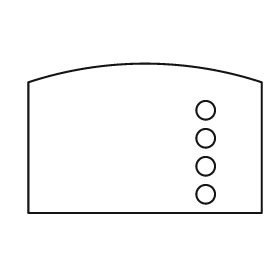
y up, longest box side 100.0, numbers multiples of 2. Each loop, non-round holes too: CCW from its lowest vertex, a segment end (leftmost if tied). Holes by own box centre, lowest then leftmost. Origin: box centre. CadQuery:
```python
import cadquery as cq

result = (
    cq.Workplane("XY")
    .moveTo(-50.0, -32.0)
    .lineTo(50.0, -32.0)
    .lineTo(50.0, 24.0)
    .threePointArc((0.0, 32.0), (-50.0, 24.0))
    .close()
    .moveTo(26.0, -24.0)
    .circle(4.0)
    .moveTo(26.0, -12.0)
    .circle(4.0)
    .moveTo(26.0, 0.0)
    .circle(4.0)
    .moveTo(26.0, 12.0)
    .circle(4.0)
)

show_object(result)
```